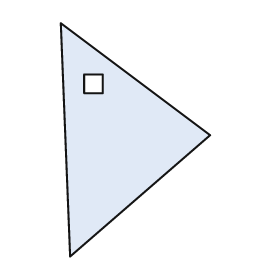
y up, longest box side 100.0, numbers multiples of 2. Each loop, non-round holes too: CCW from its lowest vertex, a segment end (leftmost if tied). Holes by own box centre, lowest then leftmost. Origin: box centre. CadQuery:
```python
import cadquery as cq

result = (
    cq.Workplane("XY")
    .moveTo(-28.0, -50.0)
    .lineTo(32.0, 2.0)
    .lineTo(-32.0, 50.0)
    .close()
    .moveTo(-22.0, 20.0)
    .lineTo(-14.0, 20.0)
    .lineTo(-14.0, 28.0)
    .lineTo(-22.0, 28.0)
    .close()
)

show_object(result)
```